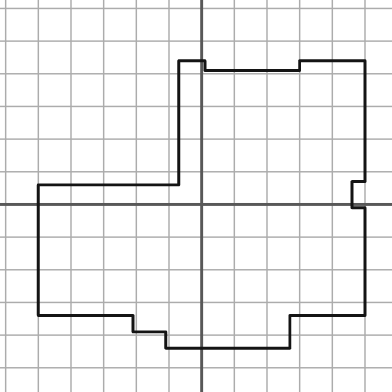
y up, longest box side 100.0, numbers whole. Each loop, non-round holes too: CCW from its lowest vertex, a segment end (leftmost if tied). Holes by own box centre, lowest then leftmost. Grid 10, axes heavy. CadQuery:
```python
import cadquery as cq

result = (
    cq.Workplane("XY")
    .moveTo(-11.0, -44.0)
    .lineTo(27.0, -44.0)
    .lineTo(27.0, -34.0)
    .lineTo(50.0, -34.0)
    .lineTo(50.0, -1.0)
    .lineTo(46.0, -1.0)
    .lineTo(46.0, 7.0)
    .lineTo(50.0, 7.0)
    .lineTo(50.0, 44.0)
    .lineTo(30.0, 44.0)
    .lineTo(30.0, 41.0)
    .lineTo(1.0, 41.0)
    .lineTo(1.0, 44.0)
    .lineTo(-7.0, 44.0)
    .lineTo(-7.0, 6.0)
    .lineTo(-50.0, 6.0)
    .lineTo(-50.0, -34.0)
    .lineTo(-21.0, -34.0)
    .lineTo(-21.0, -39.0)
    .lineTo(-11.0, -39.0)
    .close()
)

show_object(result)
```